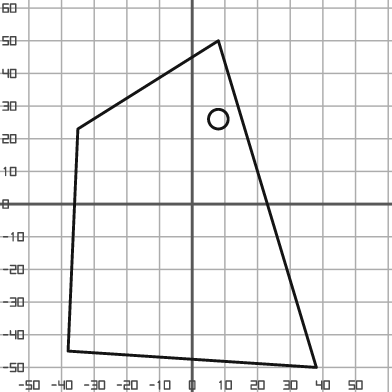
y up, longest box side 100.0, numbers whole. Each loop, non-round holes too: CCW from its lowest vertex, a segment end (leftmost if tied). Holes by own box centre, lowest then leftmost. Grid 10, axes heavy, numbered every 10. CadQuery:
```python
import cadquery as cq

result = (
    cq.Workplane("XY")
    .moveTo(38.0, -50.0)
    .lineTo(8.0, 50.0)
    .lineTo(-35.0, 23.0)
    .lineTo(-38.0, -45.0)
    .close()
    .moveTo(8.0, 26.0)
    .circle(3.0)
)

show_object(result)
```